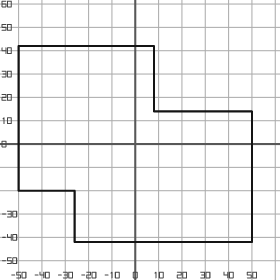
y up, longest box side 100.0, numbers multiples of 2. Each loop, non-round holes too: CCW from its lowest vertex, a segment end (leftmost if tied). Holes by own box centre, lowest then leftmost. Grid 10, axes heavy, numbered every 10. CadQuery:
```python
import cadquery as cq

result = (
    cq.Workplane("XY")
    .moveTo(-26.0, -42.0)
    .lineTo(50.0, -42.0)
    .lineTo(50.0, 14.0)
    .lineTo(8.0, 14.0)
    .lineTo(8.0, 42.0)
    .lineTo(-50.0, 42.0)
    .lineTo(-50.0, -20.0)
    .lineTo(-26.0, -20.0)
    .close()
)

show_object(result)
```